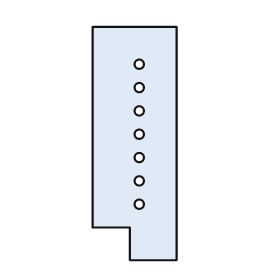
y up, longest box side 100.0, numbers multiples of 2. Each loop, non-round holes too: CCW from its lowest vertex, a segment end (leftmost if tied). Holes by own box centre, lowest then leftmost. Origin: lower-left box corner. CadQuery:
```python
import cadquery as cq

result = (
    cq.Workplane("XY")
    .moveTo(16.0, 0.0)
    .lineTo(36.0, 0.0)
    .lineTo(36.0, 100.0)
    .lineTo(0.0, 100.0)
    .lineTo(0.0, 14.0)
    .lineTo(16.0, 14.0)
    .close()
    .moveTo(20.0, 24.0)
    .circle(2.0)
    .moveTo(20.0, 34.0)
    .circle(2.0)
    .moveTo(20.0, 44.0)
    .circle(2.0)
    .moveTo(20.0, 54.0)
    .circle(2.0)
    .moveTo(20.0, 64.0)
    .circle(2.0)
    .moveTo(20.0, 74.0)
    .circle(2.0)
    .moveTo(20.0, 84.0)
    .circle(2.0)
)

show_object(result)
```